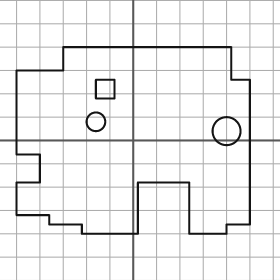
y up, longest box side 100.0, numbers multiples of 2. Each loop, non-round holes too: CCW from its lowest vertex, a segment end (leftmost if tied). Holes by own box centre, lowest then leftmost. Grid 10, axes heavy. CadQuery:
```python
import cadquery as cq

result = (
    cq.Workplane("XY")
    .moveTo(-22.0, -40.0)
    .lineTo(2.0, -40.0)
    .lineTo(2.0, -18.0)
    .lineTo(24.0, -18.0)
    .lineTo(24.0, -40.0)
    .lineTo(40.0, -40.0)
    .lineTo(40.0, -36.0)
    .lineTo(50.0, -36.0)
    .lineTo(50.0, 26.0)
    .lineTo(42.0, 26.0)
    .lineTo(42.0, 40.0)
    .lineTo(-30.0, 40.0)
    .lineTo(-30.0, 30.0)
    .lineTo(-50.0, 30.0)
    .lineTo(-50.0, -6.0)
    .lineTo(-40.0, -6.0)
    .lineTo(-40.0, -18.0)
    .lineTo(-50.0, -18.0)
    .lineTo(-50.0, -32.0)
    .lineTo(-36.0, -32.0)
    .lineTo(-36.0, -36.0)
    .lineTo(-22.0, -36.0)
    .close()
    .moveTo(40.0, 4.0)
    .circle(6.0)
    .moveTo(-16.0, 8.0)
    .circle(4.0)
    .moveTo(-16.0, 18.0)
    .lineTo(-8.0, 18.0)
    .lineTo(-8.0, 26.0)
    .lineTo(-16.0, 26.0)
    .close()
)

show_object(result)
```